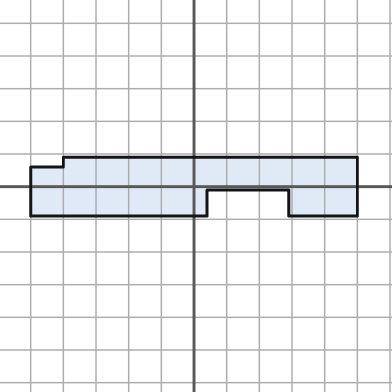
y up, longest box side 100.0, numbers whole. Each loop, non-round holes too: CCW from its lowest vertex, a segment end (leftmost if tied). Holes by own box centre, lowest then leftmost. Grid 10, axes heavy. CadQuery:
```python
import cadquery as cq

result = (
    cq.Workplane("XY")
    .moveTo(-50.0, -9.0)
    .lineTo(4.0, -9.0)
    .lineTo(4.0, -1.0)
    .lineTo(29.0, -1.0)
    .lineTo(29.0, -9.0)
    .lineTo(50.0, -9.0)
    .lineTo(50.0, 9.0)
    .lineTo(-40.0, 9.0)
    .lineTo(-40.0, 6.0)
    .lineTo(-50.0, 6.0)
    .close()
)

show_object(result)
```